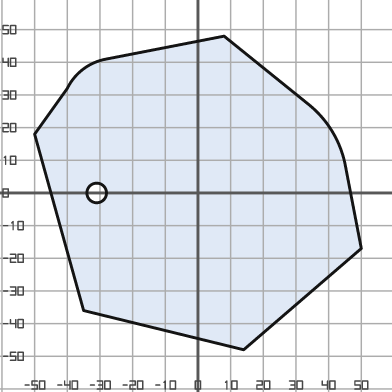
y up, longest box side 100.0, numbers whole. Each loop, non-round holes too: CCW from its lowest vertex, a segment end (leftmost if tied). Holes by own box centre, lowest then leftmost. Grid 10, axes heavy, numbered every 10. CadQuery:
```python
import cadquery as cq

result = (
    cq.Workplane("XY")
    .moveTo(14.0, -48.0)
    .lineTo(50.0, -17.0)
    .lineTo(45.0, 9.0)
    .threePointArc((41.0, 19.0), (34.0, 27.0))
    .lineTo(8.0, 48.0)
    .lineTo(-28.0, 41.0)
    .threePointArc((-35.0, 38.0), (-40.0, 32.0))
    .lineTo(-50.0, 18.0)
    .lineTo(-35.0, -36.0)
    .close()
    .moveTo(-31.0, 0.0)
    .circle(3.0)
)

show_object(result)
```